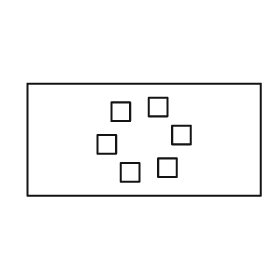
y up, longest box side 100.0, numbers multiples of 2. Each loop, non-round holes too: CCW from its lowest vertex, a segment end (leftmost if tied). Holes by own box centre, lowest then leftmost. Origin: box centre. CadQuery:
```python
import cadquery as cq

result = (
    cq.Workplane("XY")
    .moveTo(-50.0, -24.0)
    .lineTo(50.0, -24.0)
    .lineTo(50.0, 24.0)
    .lineTo(-50.0, 24.0)
    .close()
    .moveTo(-10.0, -18.0)
    .lineTo(-2.0, -18.0)
    .lineTo(-2.0, -10.0)
    .lineTo(-10.0, -10.0)
    .close()
    .moveTo(6.0, -16.0)
    .lineTo(14.0, -16.0)
    .lineTo(14.0, -8.0)
    .lineTo(6.0, -8.0)
    .close()
    .moveTo(-20.0, -6.0)
    .lineTo(-12.0, -6.0)
    .lineTo(-12.0, 2.0)
    .lineTo(-20.0, 2.0)
    .close()
    .moveTo(12.0, -2.0)
    .lineTo(20.0, -2.0)
    .lineTo(20.0, 6.0)
    .lineTo(12.0, 6.0)
    .close()
    .moveTo(-14.0, 8.0)
    .lineTo(-6.0, 8.0)
    .lineTo(-6.0, 16.0)
    .lineTo(-14.0, 16.0)
    .close()
    .moveTo(2.0, 10.0)
    .lineTo(10.0, 10.0)
    .lineTo(10.0, 18.0)
    .lineTo(2.0, 18.0)
    .close()
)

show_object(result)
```